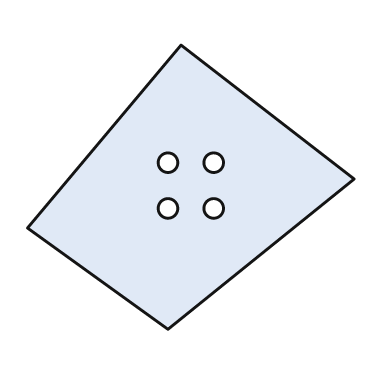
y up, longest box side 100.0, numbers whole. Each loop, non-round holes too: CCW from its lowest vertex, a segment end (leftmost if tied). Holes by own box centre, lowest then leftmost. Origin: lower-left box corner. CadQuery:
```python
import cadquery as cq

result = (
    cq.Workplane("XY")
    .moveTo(43.0, 0.0)
    .lineTo(100.0, 46.0)
    .lineTo(47.0, 87.0)
    .lineTo(0.0, 31.0)
    .close()
    .moveTo(43.0, 37.0)
    .circle(3.0)
    .moveTo(57.0, 37.0)
    .circle(3.0)
    .moveTo(43.0, 51.0)
    .circle(3.0)
    .moveTo(57.0, 51.0)
    .circle(3.0)
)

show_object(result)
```